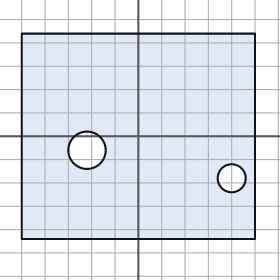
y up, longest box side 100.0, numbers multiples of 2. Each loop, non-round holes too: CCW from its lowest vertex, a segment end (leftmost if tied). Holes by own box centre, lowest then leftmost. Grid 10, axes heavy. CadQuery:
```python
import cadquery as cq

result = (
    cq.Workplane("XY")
    .moveTo(-50.0, -44.0)
    .lineTo(50.0, -44.0)
    .lineTo(50.0, 44.0)
    .lineTo(-50.0, 44.0)
    .close()
    .moveTo(40.0, -18.0)
    .circle(6.0)
    .moveTo(-22.0, -6.0)
    .circle(8.0)
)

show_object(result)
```